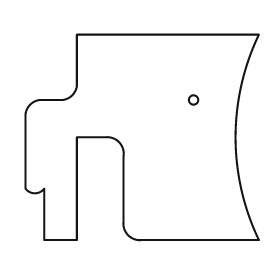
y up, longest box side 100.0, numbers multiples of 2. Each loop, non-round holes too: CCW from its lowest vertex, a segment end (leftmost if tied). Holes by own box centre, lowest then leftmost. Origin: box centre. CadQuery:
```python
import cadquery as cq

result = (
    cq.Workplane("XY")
    .moveTo(-42.0, -44.0)
    .lineTo(-28.0, -44.0)
    .lineTo(-28.0, 0.0)
    .lineTo(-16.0, 0.0)
    .threePointArc((-10.0, -2.0), (-8.0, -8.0))
    .lineTo(-8.0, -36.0)
    .threePointArc((-6.0, -42.0), (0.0, -44.0))
    .lineTo(50.0, -44.0)
    .threePointArc((40.0, 0.0), (50.0, 44.0))
    .lineTo(-28.0, 44.0)
    .lineTo(-28.0, 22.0)
    .threePointArc((-30.0, 18.0), (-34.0, 16.0))
    .lineTo(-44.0, 16.0)
    .threePointArc((-48.0, 14.0), (-50.0, 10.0))
    .lineTo(-50.0, -22.0)
    .threePointArc((-46.0, -24.0), (-42.0, -22.0))
    .close()
    .moveTo(22.0, 16.0)
    .circle(2.0)
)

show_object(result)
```